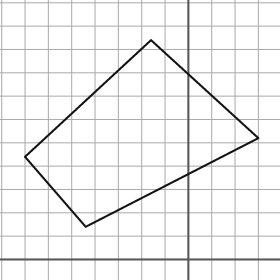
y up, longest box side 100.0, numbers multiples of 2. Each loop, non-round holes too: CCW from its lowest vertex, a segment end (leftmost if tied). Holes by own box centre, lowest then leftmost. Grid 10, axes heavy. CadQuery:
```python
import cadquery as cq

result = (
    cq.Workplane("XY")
    .moveTo(-44.0, 14.0)
    .lineTo(30.0, 52.0)
    .lineTo(-16.0, 94.0)
    .lineTo(-70.0, 44.0)
    .close()
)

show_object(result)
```